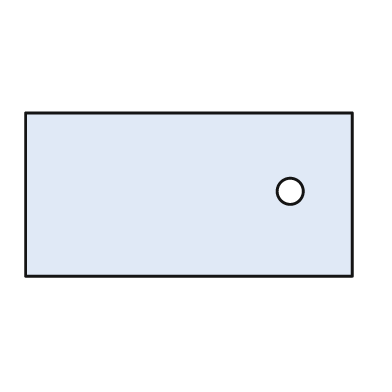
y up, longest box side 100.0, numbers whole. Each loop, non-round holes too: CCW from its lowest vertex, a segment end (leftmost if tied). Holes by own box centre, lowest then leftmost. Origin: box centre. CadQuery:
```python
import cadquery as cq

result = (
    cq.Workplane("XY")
    .moveTo(-50.0, -25.0)
    .lineTo(50.0, -25.0)
    .lineTo(50.0, 25.0)
    .lineTo(-50.0, 25.0)
    .close()
    .moveTo(31.0, 1.0)
    .circle(4.0)
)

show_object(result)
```